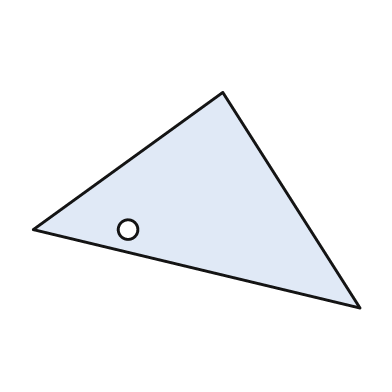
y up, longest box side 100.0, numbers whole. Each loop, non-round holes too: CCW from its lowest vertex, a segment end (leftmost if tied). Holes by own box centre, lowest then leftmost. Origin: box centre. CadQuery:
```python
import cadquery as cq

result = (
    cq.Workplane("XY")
    .moveTo(50.0, -33.0)
    .lineTo(8.0, 33.0)
    .lineTo(-50.0, -9.0)
    .close()
    .moveTo(-21.0, -9.0)
    .circle(3.0)
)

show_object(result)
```